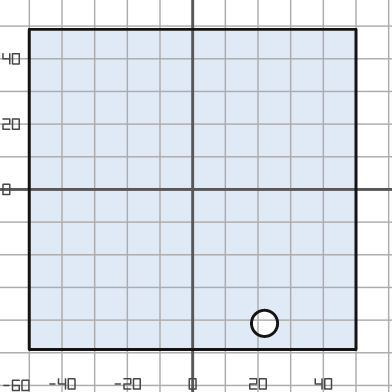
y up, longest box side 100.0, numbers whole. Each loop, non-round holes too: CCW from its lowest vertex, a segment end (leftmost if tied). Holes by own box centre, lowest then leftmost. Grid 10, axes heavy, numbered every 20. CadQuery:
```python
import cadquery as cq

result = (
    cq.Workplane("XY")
    .moveTo(-50.0, -49.0)
    .lineTo(50.0, -49.0)
    .lineTo(50.0, 49.0)
    .lineTo(-50.0, 49.0)
    .close()
    .moveTo(22.0, -41.0)
    .circle(4.0)
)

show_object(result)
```